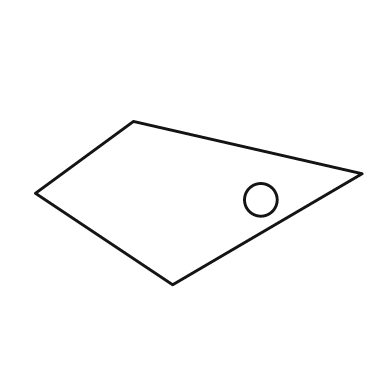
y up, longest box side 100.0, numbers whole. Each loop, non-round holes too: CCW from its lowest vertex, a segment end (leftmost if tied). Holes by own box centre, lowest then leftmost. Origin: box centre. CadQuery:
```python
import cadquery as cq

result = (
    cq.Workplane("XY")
    .moveTo(-8.0, -25.0)
    .lineTo(50.0, 9.0)
    .lineTo(-20.0, 25.0)
    .lineTo(-50.0, 3.0)
    .close()
    .moveTo(19.0, 1.0)
    .circle(5.0)
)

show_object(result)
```